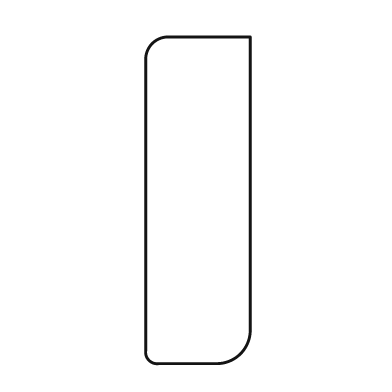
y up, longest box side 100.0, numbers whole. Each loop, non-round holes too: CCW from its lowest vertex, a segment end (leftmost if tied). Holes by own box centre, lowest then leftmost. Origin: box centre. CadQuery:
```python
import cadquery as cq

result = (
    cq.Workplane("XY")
    .moveTo(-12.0, -50.0)
    .lineTo(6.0, -50.0)
    .threePointArc((13.0, -47.0), (16.0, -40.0))
    .lineTo(16.0, 50.0)
    .lineTo(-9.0, 50.0)
    .threePointArc((-14.0, 48.0), (-16.0, 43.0))
    .lineTo(-16.0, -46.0)
    .threePointArc((-15.0, -49.0), (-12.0, -50.0))
    .close()
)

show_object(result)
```